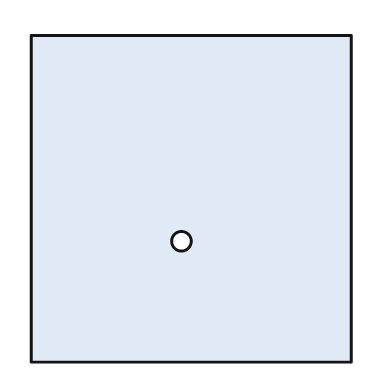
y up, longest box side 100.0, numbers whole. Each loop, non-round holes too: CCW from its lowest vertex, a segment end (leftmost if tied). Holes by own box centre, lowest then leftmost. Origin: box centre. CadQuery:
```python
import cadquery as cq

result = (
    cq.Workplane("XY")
    .moveTo(-49.0, -50.0)
    .lineTo(49.0, -50.0)
    .lineTo(49.0, 50.0)
    .lineTo(-49.0, 50.0)
    .close()
    .moveTo(-3.0, -13.0)
    .circle(3.0)
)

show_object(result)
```